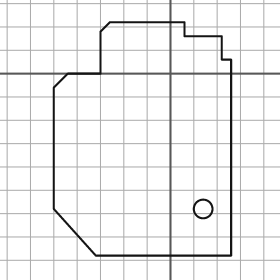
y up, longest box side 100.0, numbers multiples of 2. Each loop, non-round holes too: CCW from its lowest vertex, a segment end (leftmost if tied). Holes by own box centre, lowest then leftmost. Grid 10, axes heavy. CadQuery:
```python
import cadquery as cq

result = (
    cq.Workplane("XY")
    .moveTo(-32.0, -78.0)
    .lineTo(26.0, -78.0)
    .lineTo(26.0, 6.0)
    .lineTo(22.0, 6.0)
    .lineTo(22.0, 16.0)
    .lineTo(6.0, 16.0)
    .lineTo(6.0, 22.0)
    .lineTo(-26.0, 22.0)
    .lineTo(-30.0, 18.0)
    .lineTo(-30.0, 0.0)
    .lineTo(-44.0, 0.0)
    .lineTo(-50.0, -6.0)
    .lineTo(-50.0, -58.0)
    .close()
    .moveTo(14.0, -58.0)
    .circle(4.0)
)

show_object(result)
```